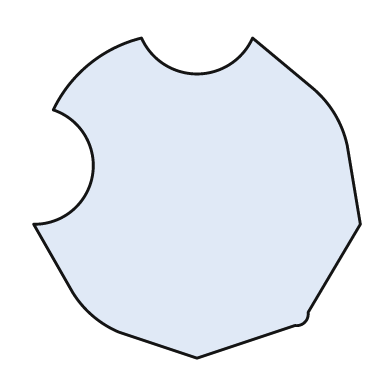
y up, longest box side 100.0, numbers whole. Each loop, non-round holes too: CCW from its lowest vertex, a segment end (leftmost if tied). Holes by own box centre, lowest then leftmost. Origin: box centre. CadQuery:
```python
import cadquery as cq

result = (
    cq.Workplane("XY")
    .moveTo(0.0, -49.0)
    .lineTo(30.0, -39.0)
    .threePointArc((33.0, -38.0), (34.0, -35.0))
    .lineTo(50.0, -8.0)
    .lineTo(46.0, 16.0)
    .threePointArc((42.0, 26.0), (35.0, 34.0))
    .lineTo(17.0, 49.0)
    .threePointArc((0.0, 38.0), (-17.0, 49.0))
    .threePointArc((-33.0, 41.0), (-44.0, 27.0))
    .threePointArc((-32.0, 7.0), (-50.0, -8.0))
    .lineTo(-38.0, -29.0)
    .threePointArc((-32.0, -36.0), (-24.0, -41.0))
    .close()
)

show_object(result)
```